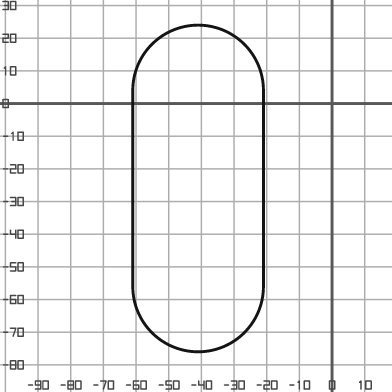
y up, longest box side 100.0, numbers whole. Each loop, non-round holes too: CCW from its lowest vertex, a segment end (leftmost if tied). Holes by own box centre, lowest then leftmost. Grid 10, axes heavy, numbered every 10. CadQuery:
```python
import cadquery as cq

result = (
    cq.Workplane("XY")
    .moveTo(-61.0, -56.0)
    .threePointArc((-41.0, -76.0), (-21.0, -56.0))
    .lineTo(-21.0, 4.0)
    .threePointArc((-41.0, 24.0), (-61.0, 4.0))
    .close()
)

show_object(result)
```